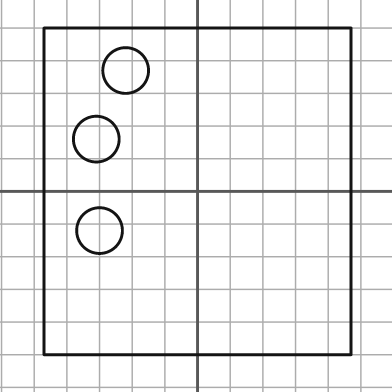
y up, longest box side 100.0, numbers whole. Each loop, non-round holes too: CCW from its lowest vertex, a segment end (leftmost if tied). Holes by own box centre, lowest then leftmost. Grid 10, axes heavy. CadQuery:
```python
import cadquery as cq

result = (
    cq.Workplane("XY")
    .moveTo(-47.0, -50.0)
    .lineTo(47.0, -50.0)
    .lineTo(47.0, 50.0)
    .lineTo(-47.0, 50.0)
    .close()
    .moveTo(-30.0, -12.0)
    .circle(7.0)
    .moveTo(-31.0, 16.0)
    .circle(7.0)
    .moveTo(-22.0, 37.0)
    .circle(7.0)
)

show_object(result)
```